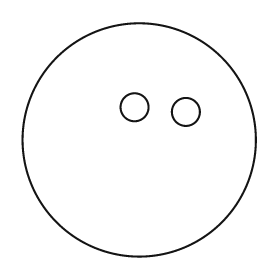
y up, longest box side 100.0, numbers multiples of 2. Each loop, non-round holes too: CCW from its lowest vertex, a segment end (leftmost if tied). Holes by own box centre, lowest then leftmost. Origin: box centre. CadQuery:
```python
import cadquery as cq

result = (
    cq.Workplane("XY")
    .moveTo(0.0, 0.0)
    .circle(50.0)
    .moveTo(20.0, 12.0)
    .circle(6.0)
    .moveTo(-2.0, 14.0)
    .circle(6.0)
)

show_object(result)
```